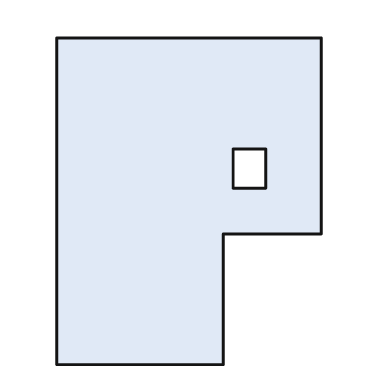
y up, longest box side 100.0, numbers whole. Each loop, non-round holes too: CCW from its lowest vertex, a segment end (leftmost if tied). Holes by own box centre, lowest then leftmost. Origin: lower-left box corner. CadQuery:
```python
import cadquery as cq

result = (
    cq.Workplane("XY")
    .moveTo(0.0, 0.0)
    .lineTo(51.0, 0.0)
    .lineTo(51.0, 40.0)
    .lineTo(81.0, 40.0)
    .lineTo(81.0, 100.0)
    .lineTo(0.0, 100.0)
    .close()
    .moveTo(54.0, 54.0)
    .lineTo(64.0, 54.0)
    .lineTo(64.0, 66.0)
    .lineTo(54.0, 66.0)
    .close()
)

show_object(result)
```